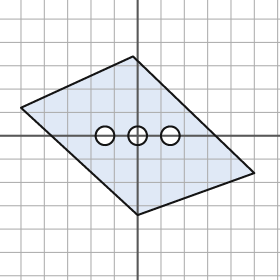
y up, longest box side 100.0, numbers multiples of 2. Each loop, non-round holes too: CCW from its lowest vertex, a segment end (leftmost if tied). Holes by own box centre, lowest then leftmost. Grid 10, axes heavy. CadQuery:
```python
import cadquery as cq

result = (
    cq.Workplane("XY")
    .moveTo(0.0, -34.0)
    .lineTo(50.0, -16.0)
    .lineTo(-2.0, 34.0)
    .lineTo(-50.0, 12.0)
    .close()
    .moveTo(-14.0, 0.0)
    .circle(4.0)
    .moveTo(0.0, 0.0)
    .circle(4.0)
    .moveTo(14.0, 0.0)
    .circle(4.0)
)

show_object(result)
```